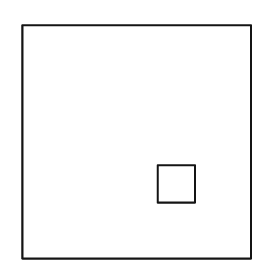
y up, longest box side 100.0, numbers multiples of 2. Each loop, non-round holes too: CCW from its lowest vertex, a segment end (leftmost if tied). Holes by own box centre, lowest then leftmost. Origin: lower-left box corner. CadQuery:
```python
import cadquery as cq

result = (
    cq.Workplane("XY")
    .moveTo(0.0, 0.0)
    .lineTo(98.0, 0.0)
    .lineTo(98.0, 100.0)
    .lineTo(0.0, 100.0)
    .close()
    .moveTo(58.0, 24.0)
    .lineTo(74.0, 24.0)
    .lineTo(74.0, 40.0)
    .lineTo(58.0, 40.0)
    .close()
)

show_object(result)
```